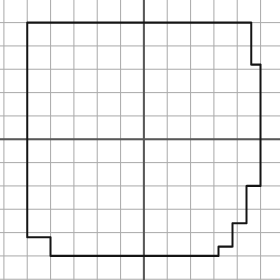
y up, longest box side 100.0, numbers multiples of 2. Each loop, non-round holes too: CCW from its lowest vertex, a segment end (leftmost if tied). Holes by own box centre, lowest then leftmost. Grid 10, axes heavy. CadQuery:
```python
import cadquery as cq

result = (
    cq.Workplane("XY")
    .moveTo(-40.0, -50.0)
    .lineTo(32.0, -50.0)
    .lineTo(32.0, -46.0)
    .lineTo(38.0, -46.0)
    .lineTo(38.0, -36.0)
    .lineTo(44.0, -36.0)
    .lineTo(44.0, -20.0)
    .lineTo(50.0, -20.0)
    .lineTo(50.0, 32.0)
    .lineTo(46.0, 32.0)
    .lineTo(46.0, 50.0)
    .lineTo(-50.0, 50.0)
    .lineTo(-50.0, -42.0)
    .lineTo(-40.0, -42.0)
    .close()
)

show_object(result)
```